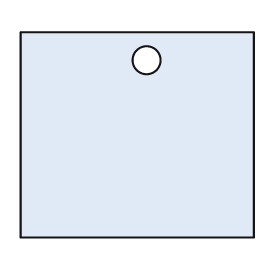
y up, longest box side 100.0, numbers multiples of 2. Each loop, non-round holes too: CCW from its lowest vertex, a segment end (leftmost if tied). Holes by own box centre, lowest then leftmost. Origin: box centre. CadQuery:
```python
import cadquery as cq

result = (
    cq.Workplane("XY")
    .moveTo(-50.0, -44.0)
    .lineTo(50.0, -44.0)
    .lineTo(50.0, 44.0)
    .lineTo(-50.0, 44.0)
    .close()
    .moveTo(4.0, 32.0)
    .circle(6.0)
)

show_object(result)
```